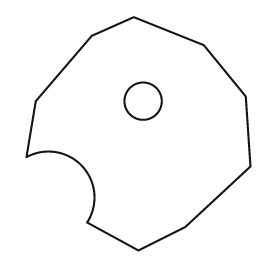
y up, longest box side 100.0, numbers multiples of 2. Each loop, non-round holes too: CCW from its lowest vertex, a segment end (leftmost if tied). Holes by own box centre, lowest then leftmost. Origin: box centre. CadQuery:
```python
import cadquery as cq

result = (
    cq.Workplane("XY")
    .moveTo(0.0, -50.0)
    .lineTo(20.0, -40.0)
    .lineTo(48.0, -14.0)
    .lineTo(46.0, 16.0)
    .lineTo(28.0, 38.0)
    .lineTo(-2.0, 50.0)
    .lineTo(-20.0, 42.0)
    .lineTo(-44.0, 14.0)
    .lineTo(-48.0, -10.0)
    .threePointArc((-24.0, -14.0), (-22.0, -38.0))
    .close()
    .moveTo(2.0, 14.0)
    .circle(8.0)
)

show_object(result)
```